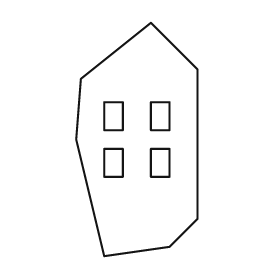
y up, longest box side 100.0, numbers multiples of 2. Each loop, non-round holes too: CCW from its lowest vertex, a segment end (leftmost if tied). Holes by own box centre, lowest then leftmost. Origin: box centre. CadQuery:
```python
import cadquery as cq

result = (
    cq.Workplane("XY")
    .moveTo(-14.0, -50.0)
    .lineTo(14.0, -46.0)
    .lineTo(26.0, -34.0)
    .lineTo(26.0, 30.0)
    .lineTo(6.0, 50.0)
    .lineTo(-24.0, 26.0)
    .lineTo(-26.0, 0.0)
    .close()
    .moveTo(-14.0, -16.0)
    .lineTo(-6.0, -16.0)
    .lineTo(-6.0, -4.0)
    .lineTo(-14.0, -4.0)
    .close()
    .moveTo(6.0, -16.0)
    .lineTo(14.0, -16.0)
    .lineTo(14.0, -4.0)
    .lineTo(6.0, -4.0)
    .close()
    .moveTo(-14.0, 4.0)
    .lineTo(-6.0, 4.0)
    .lineTo(-6.0, 16.0)
    .lineTo(-14.0, 16.0)
    .close()
    .moveTo(6.0, 4.0)
    .lineTo(14.0, 4.0)
    .lineTo(14.0, 16.0)
    .lineTo(6.0, 16.0)
    .close()
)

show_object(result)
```